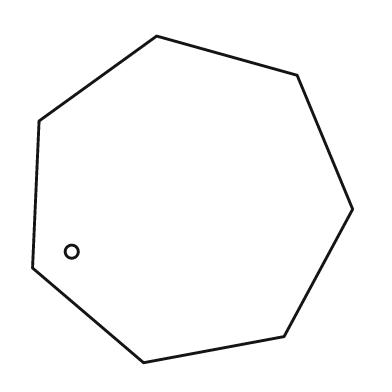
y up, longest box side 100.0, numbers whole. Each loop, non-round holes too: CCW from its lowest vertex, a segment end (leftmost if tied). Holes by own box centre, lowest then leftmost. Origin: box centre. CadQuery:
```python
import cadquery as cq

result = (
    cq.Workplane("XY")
    .moveTo(-15.0, -50.0)
    .lineTo(28.0, -42.0)
    .lineTo(49.0, -3.0)
    .lineTo(32.0, 38.0)
    .lineTo(-11.0, 50.0)
    .lineTo(-47.0, 24.0)
    .lineTo(-49.0, -21.0)
    .close()
    .moveTo(-37.0, -16.0)
    .circle(2.0)
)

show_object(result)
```